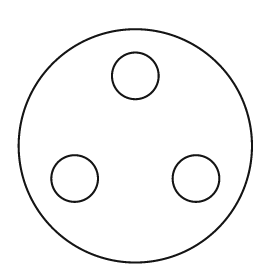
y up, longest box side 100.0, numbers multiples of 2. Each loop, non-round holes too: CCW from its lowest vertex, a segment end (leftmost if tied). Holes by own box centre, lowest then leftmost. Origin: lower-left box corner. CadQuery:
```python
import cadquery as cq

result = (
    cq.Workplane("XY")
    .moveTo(50.0, 50.0)
    .circle(50.0)
    .moveTo(24.0, 36.0)
    .circle(10.0)
    .moveTo(76.0, 36.0)
    .circle(10.0)
    .moveTo(50.0, 80.0)
    .circle(10.0)
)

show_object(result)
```